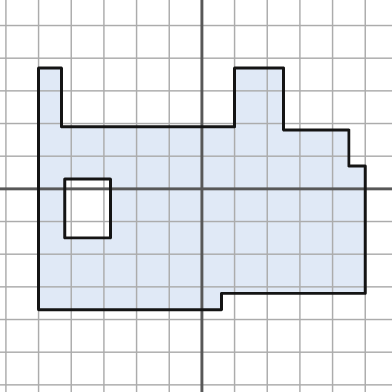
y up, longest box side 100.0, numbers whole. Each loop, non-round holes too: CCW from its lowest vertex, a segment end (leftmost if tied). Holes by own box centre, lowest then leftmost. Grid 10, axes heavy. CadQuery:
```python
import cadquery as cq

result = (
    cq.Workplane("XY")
    .moveTo(-50.0, -37.0)
    .lineTo(6.0, -37.0)
    .lineTo(6.0, -32.0)
    .lineTo(50.0, -32.0)
    .lineTo(50.0, 7.0)
    .lineTo(45.0, 7.0)
    .lineTo(45.0, 18.0)
    .lineTo(25.0, 18.0)
    .lineTo(25.0, 37.0)
    .lineTo(10.0, 37.0)
    .lineTo(10.0, 19.0)
    .lineTo(-43.0, 19.0)
    .lineTo(-43.0, 37.0)
    .lineTo(-50.0, 37.0)
    .close()
    .moveTo(-42.0, -15.0)
    .lineTo(-28.0, -15.0)
    .lineTo(-28.0, 3.0)
    .lineTo(-42.0, 3.0)
    .close()
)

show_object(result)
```